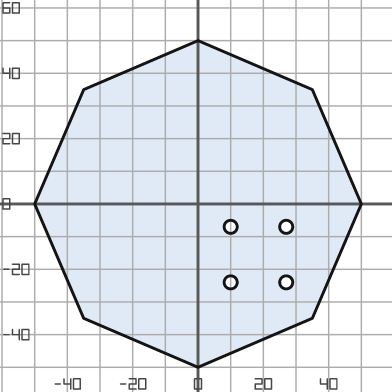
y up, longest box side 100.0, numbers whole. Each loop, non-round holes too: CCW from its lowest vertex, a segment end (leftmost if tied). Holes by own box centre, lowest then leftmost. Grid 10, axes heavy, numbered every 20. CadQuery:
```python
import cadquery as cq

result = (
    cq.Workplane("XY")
    .moveTo(0.0, -50.0)
    .lineTo(35.0, -35.0)
    .lineTo(50.0, 0.0)
    .lineTo(35.0, 35.0)
    .lineTo(0.0, 50.0)
    .lineTo(-35.0, 35.0)
    .lineTo(-50.0, 0.0)
    .lineTo(-35.0, -35.0)
    .close()
    .moveTo(10.0, -24.0)
    .circle(2.0)
    .moveTo(27.0, -24.0)
    .circle(2.0)
    .moveTo(10.0, -7.0)
    .circle(2.0)
    .moveTo(27.0, -7.0)
    .circle(2.0)
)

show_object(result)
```